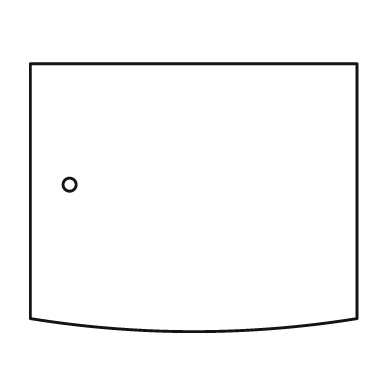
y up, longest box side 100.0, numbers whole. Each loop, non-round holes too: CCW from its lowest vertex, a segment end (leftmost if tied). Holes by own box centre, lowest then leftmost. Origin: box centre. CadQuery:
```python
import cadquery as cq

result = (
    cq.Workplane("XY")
    .moveTo(-50.0, -37.0)
    .threePointArc((0.0, -41.0), (50.0, -37.0))
    .lineTo(50.0, 41.0)
    .lineTo(-50.0, 41.0)
    .close()
    .moveTo(-38.0, 4.0)
    .circle(2.0)
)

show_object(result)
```